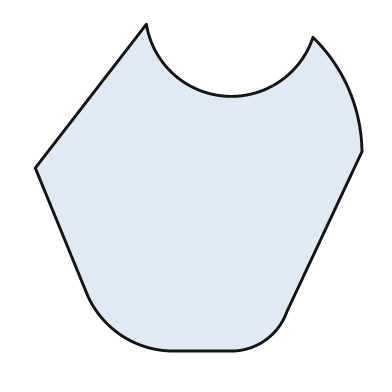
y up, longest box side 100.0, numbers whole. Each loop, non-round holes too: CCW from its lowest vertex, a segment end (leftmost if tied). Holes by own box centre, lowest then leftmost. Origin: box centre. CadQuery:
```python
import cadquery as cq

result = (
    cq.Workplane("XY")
    .moveTo(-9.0, -50.0)
    .lineTo(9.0, -50.0)
    .threePointArc((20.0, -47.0), (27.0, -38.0))
    .lineTo(50.0, 11.0)
    .threePointArc((46.0, 30.0), (35.0, 46.0))
    .threePointArc((8.0, 28.0), (-16.0, 50.0))
    .lineTo(-50.0, 6.0)
    .lineTo(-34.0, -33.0)
    .threePointArc((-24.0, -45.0), (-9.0, -50.0))
    .close()
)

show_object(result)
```